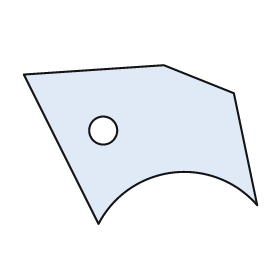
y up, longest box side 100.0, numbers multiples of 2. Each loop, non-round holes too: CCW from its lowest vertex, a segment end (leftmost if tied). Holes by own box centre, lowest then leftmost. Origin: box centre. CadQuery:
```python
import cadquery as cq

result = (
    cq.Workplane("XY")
    .moveTo(-18.0, -34.0)
    .threePointArc((14.0, -12.0), (50.0, -26.0))
    .lineTo(40.0, 22.0)
    .lineTo(10.0, 34.0)
    .lineTo(-50.0, 30.0)
    .close()
    .moveTo(-16.0, 6.0)
    .circle(6.0)
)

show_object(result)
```